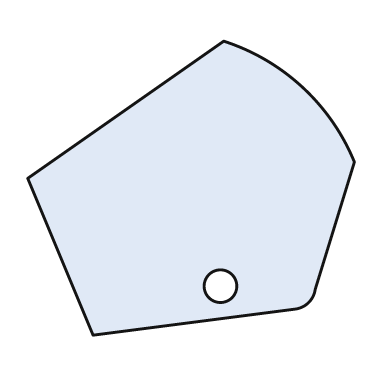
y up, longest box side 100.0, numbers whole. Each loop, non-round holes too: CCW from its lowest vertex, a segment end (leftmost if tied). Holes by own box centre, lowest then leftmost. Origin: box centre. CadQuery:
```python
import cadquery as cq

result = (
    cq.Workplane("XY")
    .moveTo(-30.0, -45.0)
    .lineTo(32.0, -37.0)
    .threePointArc((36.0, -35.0), (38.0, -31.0))
    .lineTo(50.0, 8.0)
    .threePointArc((34.0, 31.0), (10.0, 45.0))
    .lineTo(-50.0, 3.0)
    .close()
    .moveTo(9.0, -30.0)
    .circle(5.0)
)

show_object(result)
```